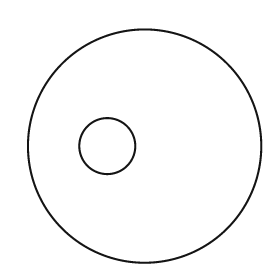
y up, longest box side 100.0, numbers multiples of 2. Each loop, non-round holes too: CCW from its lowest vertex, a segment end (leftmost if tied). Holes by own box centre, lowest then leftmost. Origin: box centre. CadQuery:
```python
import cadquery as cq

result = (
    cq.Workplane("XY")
    .moveTo(0.0, 0.0)
    .circle(50.0)
    .moveTo(-16.0, 0.0)
    .circle(12.0)
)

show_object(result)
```